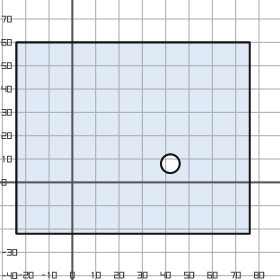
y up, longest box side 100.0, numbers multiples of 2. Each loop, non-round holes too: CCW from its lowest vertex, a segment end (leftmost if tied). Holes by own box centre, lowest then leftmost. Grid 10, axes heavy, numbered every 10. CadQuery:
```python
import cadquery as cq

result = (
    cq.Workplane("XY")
    .moveTo(-24.0, -22.0)
    .lineTo(76.0, -22.0)
    .lineTo(76.0, 60.0)
    .lineTo(-24.0, 60.0)
    .close()
    .moveTo(42.0, 8.0)
    .circle(4.0)
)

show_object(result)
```